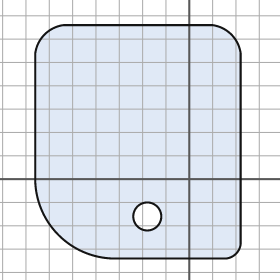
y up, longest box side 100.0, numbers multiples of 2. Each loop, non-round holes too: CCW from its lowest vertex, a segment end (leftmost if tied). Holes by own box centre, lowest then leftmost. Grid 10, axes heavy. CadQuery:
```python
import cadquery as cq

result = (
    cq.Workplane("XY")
    .moveTo(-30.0, -34.0)
    .lineTo(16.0, -34.0)
    .threePointArc((20.0, -32.0), (22.0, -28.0))
    .lineTo(22.0, 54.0)
    .threePointArc((18.0, 62.0), (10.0, 66.0))
    .lineTo(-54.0, 66.0)
    .threePointArc((-62.0, 62.0), (-66.0, 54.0))
    .lineTo(-66.0, 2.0)
    .threePointArc((-56.0, -24.0), (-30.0, -34.0))
    .close()
    .moveTo(-18.0, -16.0)
    .circle(6.0)
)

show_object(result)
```